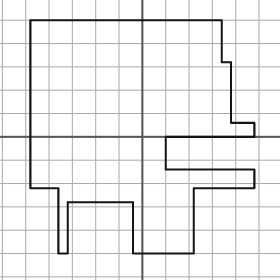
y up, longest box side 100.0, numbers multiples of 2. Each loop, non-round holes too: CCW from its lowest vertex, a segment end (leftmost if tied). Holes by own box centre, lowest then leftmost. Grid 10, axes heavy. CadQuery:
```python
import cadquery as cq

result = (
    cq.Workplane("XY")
    .moveTo(-36.0, -50.0)
    .lineTo(-32.0, -50.0)
    .lineTo(-32.0, -28.0)
    .lineTo(-4.0, -28.0)
    .lineTo(-4.0, -50.0)
    .lineTo(22.0, -50.0)
    .lineTo(22.0, -22.0)
    .lineTo(48.0, -22.0)
    .lineTo(48.0, -14.0)
    .lineTo(10.0, -14.0)
    .lineTo(10.0, 0.0)
    .lineTo(48.0, 0.0)
    .lineTo(48.0, 6.0)
    .lineTo(38.0, 6.0)
    .lineTo(38.0, 32.0)
    .lineTo(34.0, 32.0)
    .lineTo(34.0, 50.0)
    .lineTo(-48.0, 50.0)
    .lineTo(-48.0, -22.0)
    .lineTo(-36.0, -22.0)
    .close()
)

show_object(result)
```